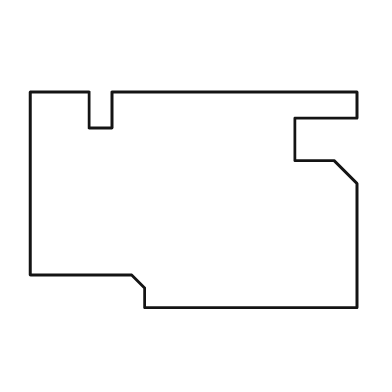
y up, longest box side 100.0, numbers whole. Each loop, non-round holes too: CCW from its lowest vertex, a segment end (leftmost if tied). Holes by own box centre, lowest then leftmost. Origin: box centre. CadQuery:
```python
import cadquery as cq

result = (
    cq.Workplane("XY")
    .moveTo(-15.0, -33.0)
    .lineTo(50.0, -33.0)
    .lineTo(50.0, 5.0)
    .lineTo(43.0, 12.0)
    .lineTo(31.0, 12.0)
    .lineTo(31.0, 25.0)
    .lineTo(50.0, 25.0)
    .lineTo(50.0, 33.0)
    .lineTo(-25.0, 33.0)
    .lineTo(-25.0, 22.0)
    .lineTo(-32.0, 22.0)
    .lineTo(-32.0, 33.0)
    .lineTo(-50.0, 33.0)
    .lineTo(-50.0, -23.0)
    .lineTo(-19.0, -23.0)
    .lineTo(-15.0, -27.0)
    .close()
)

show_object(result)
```